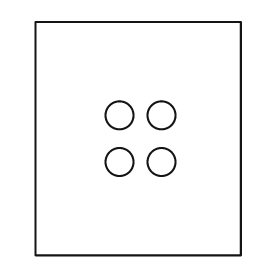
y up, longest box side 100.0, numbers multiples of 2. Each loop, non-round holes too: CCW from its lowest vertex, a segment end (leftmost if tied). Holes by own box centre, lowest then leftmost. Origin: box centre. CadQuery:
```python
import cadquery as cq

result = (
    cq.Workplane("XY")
    .moveTo(-44.0, -50.0)
    .lineTo(44.0, -50.0)
    .lineTo(44.0, 50.0)
    .lineTo(-44.0, 50.0)
    .close()
    .moveTo(-8.0, -10.0)
    .circle(6.0)
    .moveTo(10.0, -10.0)
    .circle(6.0)
    .moveTo(-8.0, 10.0)
    .circle(6.0)
    .moveTo(10.0, 10.0)
    .circle(6.0)
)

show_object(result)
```